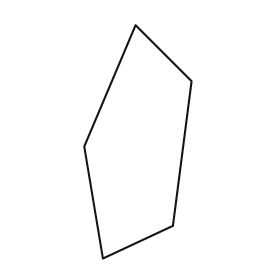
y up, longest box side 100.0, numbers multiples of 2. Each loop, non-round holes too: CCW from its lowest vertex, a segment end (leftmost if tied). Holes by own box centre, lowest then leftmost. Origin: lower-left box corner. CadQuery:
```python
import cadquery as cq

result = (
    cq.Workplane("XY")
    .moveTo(8.0, 0.0)
    .lineTo(38.0, 14.0)
    .lineTo(46.0, 76.0)
    .lineTo(22.0, 100.0)
    .lineTo(0.0, 48.0)
    .close()
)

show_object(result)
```